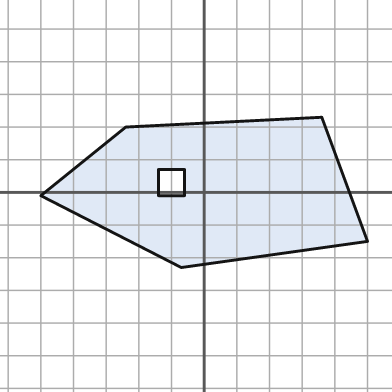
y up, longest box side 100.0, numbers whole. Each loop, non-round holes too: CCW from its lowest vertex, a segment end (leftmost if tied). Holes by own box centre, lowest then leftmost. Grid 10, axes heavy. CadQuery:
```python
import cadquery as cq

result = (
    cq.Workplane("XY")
    .moveTo(-7.0, -23.0)
    .lineTo(50.0, -15.0)
    .lineTo(36.0, 23.0)
    .lineTo(-24.0, 20.0)
    .lineTo(-50.0, -1.0)
    .close()
    .moveTo(-14.0, -1.0)
    .lineTo(-6.0, -1.0)
    .lineTo(-6.0, 7.0)
    .lineTo(-14.0, 7.0)
    .close()
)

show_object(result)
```